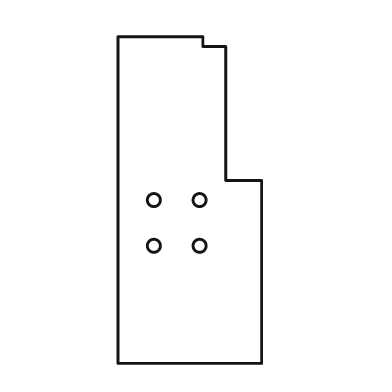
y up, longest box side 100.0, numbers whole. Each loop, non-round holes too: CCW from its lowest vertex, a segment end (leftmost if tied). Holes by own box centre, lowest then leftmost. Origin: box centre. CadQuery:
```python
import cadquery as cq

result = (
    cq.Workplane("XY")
    .moveTo(-22.0, -50.0)
    .lineTo(22.0, -50.0)
    .lineTo(22.0, 6.0)
    .lineTo(11.0, 6.0)
    .lineTo(11.0, 47.0)
    .lineTo(4.0, 47.0)
    .lineTo(4.0, 50.0)
    .lineTo(-22.0, 50.0)
    .close()
    .moveTo(-11.0, -14.0)
    .circle(2.0)
    .moveTo(3.0, -14.0)
    .circle(2.0)
    .moveTo(-11.0, 0.0)
    .circle(2.0)
    .moveTo(3.0, 0.0)
    .circle(2.0)
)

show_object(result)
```